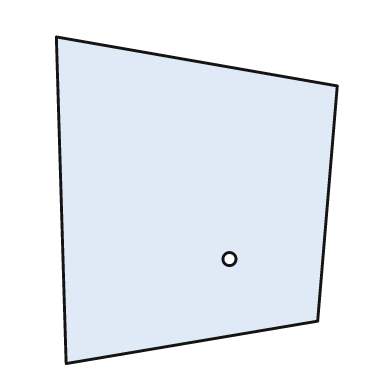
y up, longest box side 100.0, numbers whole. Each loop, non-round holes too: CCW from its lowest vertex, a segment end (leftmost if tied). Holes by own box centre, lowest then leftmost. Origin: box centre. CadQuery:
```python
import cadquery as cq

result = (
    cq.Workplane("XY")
    .moveTo(-40.0, -50.0)
    .lineTo(37.0, -37.0)
    .lineTo(43.0, 35.0)
    .lineTo(-43.0, 50.0)
    .close()
    .moveTo(10.0, -18.0)
    .circle(2.0)
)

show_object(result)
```